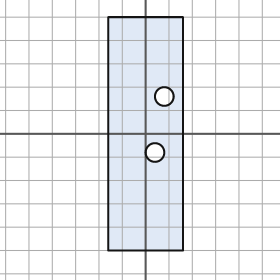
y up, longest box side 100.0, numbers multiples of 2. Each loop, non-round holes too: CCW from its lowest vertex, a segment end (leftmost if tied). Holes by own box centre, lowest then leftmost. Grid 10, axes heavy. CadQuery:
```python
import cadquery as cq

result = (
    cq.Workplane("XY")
    .moveTo(-16.0, -50.0)
    .lineTo(16.0, -50.0)
    .lineTo(16.0, 50.0)
    .lineTo(-16.0, 50.0)
    .close()
    .moveTo(4.0, -8.0)
    .circle(4.0)
    .moveTo(8.0, 16.0)
    .circle(4.0)
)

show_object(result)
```